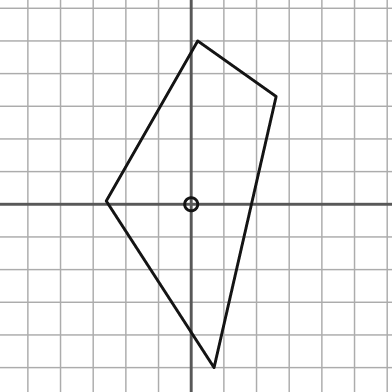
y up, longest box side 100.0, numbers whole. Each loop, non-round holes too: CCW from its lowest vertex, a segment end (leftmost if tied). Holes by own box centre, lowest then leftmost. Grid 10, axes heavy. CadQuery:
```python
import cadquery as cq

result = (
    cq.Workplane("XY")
    .moveTo(7.0, -50.0)
    .lineTo(26.0, 33.0)
    .lineTo(2.0, 50.0)
    .lineTo(-26.0, 1.0)
    .close()
    .moveTo(0.0, 0.0)
    .circle(2.0)
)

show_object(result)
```